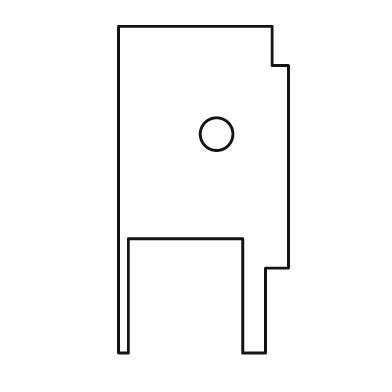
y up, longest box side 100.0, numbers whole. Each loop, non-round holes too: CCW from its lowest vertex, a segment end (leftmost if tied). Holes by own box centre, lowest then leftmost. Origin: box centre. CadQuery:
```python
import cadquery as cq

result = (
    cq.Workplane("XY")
    .moveTo(-26.0, -50.0)
    .lineTo(-23.0, -50.0)
    .lineTo(-23.0, -15.0)
    .lineTo(12.0, -15.0)
    .lineTo(12.0, -50.0)
    .lineTo(19.0, -50.0)
    .lineTo(19.0, -24.0)
    .lineTo(26.0, -24.0)
    .lineTo(26.0, 38.0)
    .lineTo(21.0, 38.0)
    .lineTo(21.0, 50.0)
    .lineTo(-26.0, 50.0)
    .close()
    .moveTo(4.0, 17.0)
    .circle(5.0)
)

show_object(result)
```